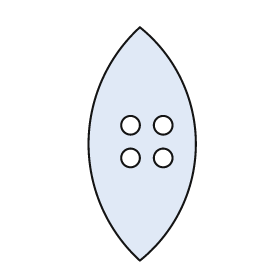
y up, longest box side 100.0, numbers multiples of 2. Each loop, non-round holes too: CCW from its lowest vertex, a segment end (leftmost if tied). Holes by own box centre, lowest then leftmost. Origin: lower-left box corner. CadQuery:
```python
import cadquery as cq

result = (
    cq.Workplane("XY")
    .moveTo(22.0, 0.0)
    .threePointArc((46.0, 50.0), (22.0, 100.0))
    .threePointArc((0.0, 50.0), (22.0, 0.0))
    .close()
    .moveTo(18.0, 44.0)
    .circle(4.0)
    .moveTo(32.0, 44.0)
    .circle(4.0)
    .moveTo(18.0, 58.0)
    .circle(4.0)
    .moveTo(32.0, 58.0)
    .circle(4.0)
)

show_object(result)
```